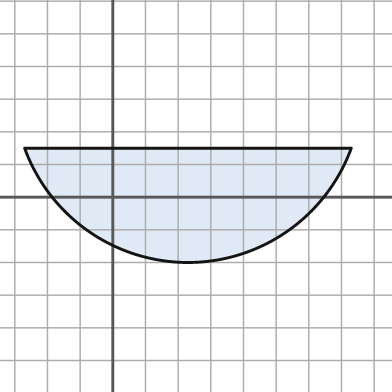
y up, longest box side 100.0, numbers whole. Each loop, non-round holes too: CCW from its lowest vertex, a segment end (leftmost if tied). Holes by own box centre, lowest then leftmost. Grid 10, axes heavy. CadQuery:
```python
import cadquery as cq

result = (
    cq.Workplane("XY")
    .moveTo(-27.0, 15.0)
    .threePointArc((23.0, -20.0), (73.0, 15.0))
    .close()
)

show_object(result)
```